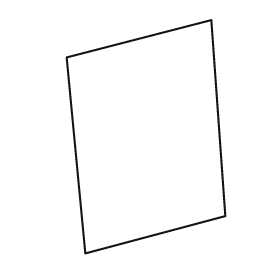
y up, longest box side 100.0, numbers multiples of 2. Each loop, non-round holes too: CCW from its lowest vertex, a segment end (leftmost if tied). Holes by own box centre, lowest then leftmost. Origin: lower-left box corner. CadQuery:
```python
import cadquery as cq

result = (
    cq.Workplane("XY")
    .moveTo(8.0, 0.0)
    .lineTo(68.0, 16.0)
    .lineTo(62.0, 100.0)
    .lineTo(0.0, 84.0)
    .close()
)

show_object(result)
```